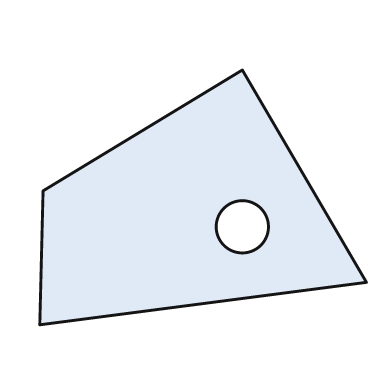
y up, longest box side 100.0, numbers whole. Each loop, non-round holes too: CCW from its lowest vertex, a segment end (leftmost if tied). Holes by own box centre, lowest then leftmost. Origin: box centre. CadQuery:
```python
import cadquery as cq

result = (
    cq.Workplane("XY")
    .moveTo(-50.0, -39.0)
    .lineTo(50.0, -26.0)
    .lineTo(12.0, 39.0)
    .lineTo(-49.0, 2.0)
    .close()
    .moveTo(12.0, -9.0)
    .circle(8.0)
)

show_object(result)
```